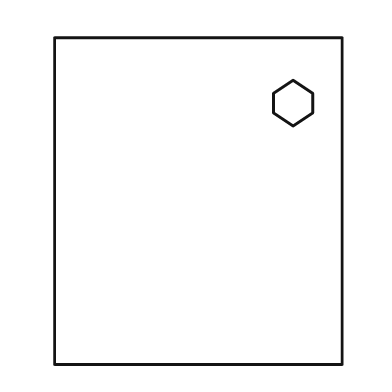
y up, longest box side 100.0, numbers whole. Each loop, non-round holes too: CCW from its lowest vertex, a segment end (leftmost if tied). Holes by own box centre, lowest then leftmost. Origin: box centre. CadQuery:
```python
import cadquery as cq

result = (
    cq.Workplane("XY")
    .moveTo(-44.0, -50.0)
    .lineTo(44.0, -50.0)
    .lineTo(44.0, 50.0)
    .lineTo(-44.0, 50.0)
    .close()
    .moveTo(29.0, 23.0)
    .lineTo(35.0, 27.0)
    .lineTo(35.0, 33.0)
    .lineTo(29.0, 37.0)
    .lineTo(23.0, 33.0)
    .lineTo(23.0, 27.0)
    .close()
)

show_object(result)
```